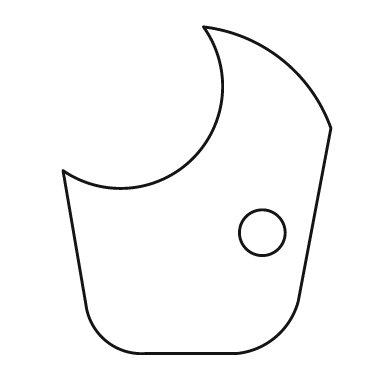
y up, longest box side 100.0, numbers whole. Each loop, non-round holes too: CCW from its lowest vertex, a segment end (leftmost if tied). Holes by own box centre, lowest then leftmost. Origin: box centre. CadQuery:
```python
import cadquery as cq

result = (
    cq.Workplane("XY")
    .moveTo(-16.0, -50.0)
    .lineTo(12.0, -50.0)
    .threePointArc((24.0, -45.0), (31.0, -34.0))
    .lineTo(41.0, 19.0)
    .threePointArc((26.0, 40.0), (2.0, 50.0))
    .threePointArc((-1.0, 10.0), (-41.0, 6.0))
    .lineTo(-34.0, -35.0)
    .threePointArc((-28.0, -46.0), (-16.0, -50.0))
    .close()
    .moveTo(20.0, -13.0)
    .circle(7.0)
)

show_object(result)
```